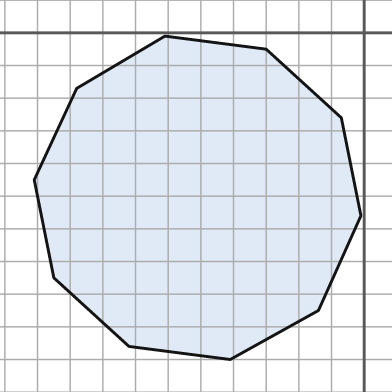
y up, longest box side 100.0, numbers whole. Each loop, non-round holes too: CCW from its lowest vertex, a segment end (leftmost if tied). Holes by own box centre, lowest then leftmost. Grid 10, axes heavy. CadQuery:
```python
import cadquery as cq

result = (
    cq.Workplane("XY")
    .moveTo(-41.0, -100.0)
    .lineTo(-14.0, -85.0)
    .lineTo(-1.0, -56.0)
    .lineTo(-7.0, -26.0)
    .lineTo(-30.0, -5.0)
    .lineTo(-61.0, -1.0)
    .lineTo(-88.0, -17.0)
    .lineTo(-101.0, -45.0)
    .lineTo(-95.0, -75.0)
    .lineTo(-72.0, -96.0)
    .close()
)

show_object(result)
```